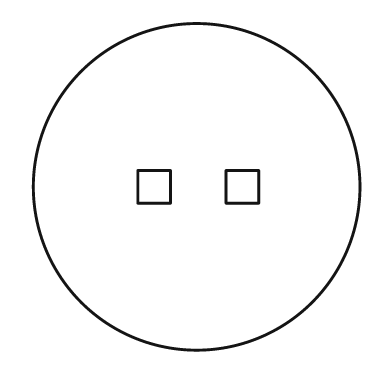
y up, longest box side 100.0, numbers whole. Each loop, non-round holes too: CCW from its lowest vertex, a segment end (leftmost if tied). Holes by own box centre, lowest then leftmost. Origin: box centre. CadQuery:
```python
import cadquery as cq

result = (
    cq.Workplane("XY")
    .moveTo(0.0, 0.0)
    .circle(50.0)
    .moveTo(-18.0, -5.0)
    .lineTo(-8.0, -5.0)
    .lineTo(-8.0, 5.0)
    .lineTo(-18.0, 5.0)
    .close()
    .moveTo(9.0, -5.0)
    .lineTo(19.0, -5.0)
    .lineTo(19.0, 5.0)
    .lineTo(9.0, 5.0)
    .close()
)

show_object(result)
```